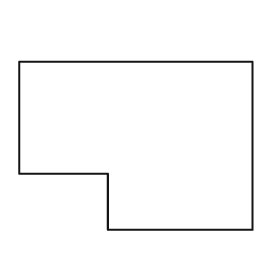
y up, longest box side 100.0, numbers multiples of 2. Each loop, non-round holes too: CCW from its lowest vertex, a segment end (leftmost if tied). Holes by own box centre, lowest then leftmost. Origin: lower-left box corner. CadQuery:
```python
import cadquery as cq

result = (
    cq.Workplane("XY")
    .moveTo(38.0, 0.0)
    .lineTo(100.0, 0.0)
    .lineTo(100.0, 72.0)
    .lineTo(0.0, 72.0)
    .lineTo(0.0, 24.0)
    .lineTo(38.0, 24.0)
    .close()
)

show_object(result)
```